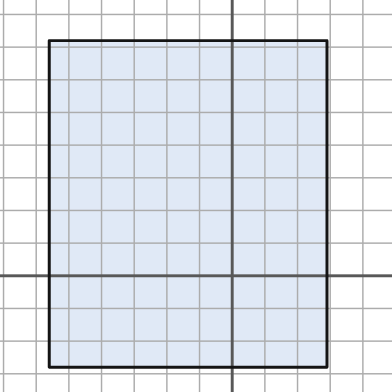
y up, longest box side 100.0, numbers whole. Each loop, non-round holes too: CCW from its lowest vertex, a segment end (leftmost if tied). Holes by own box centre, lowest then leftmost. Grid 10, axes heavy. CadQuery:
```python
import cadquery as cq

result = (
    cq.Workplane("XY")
    .moveTo(-56.0, -28.0)
    .lineTo(29.0, -28.0)
    .lineTo(29.0, 72.0)
    .lineTo(-56.0, 72.0)
    .close()
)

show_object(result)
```